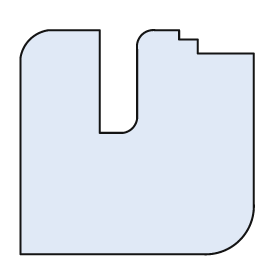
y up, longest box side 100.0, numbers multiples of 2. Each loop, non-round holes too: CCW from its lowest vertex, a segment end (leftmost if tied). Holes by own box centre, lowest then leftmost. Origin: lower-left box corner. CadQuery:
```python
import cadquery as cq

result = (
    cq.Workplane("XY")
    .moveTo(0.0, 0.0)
    .lineTo(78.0, 0.0)
    .threePointArc((94.0, 6.0), (100.0, 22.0))
    .lineTo(100.0, 86.0)
    .lineTo(76.0, 86.0)
    .lineTo(76.0, 92.0)
    .lineTo(68.0, 92.0)
    .lineTo(68.0, 96.0)
    .lineTo(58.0, 96.0)
    .threePointArc((52.0, 94.0), (50.0, 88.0))
    .lineTo(50.0, 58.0)
    .threePointArc((48.0, 54.0), (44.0, 52.0))
    .lineTo(34.0, 52.0)
    .lineTo(34.0, 96.0)
    .lineTo(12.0, 96.0)
    .threePointArc((4.0, 92.0), (0.0, 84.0))
    .close()
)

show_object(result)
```